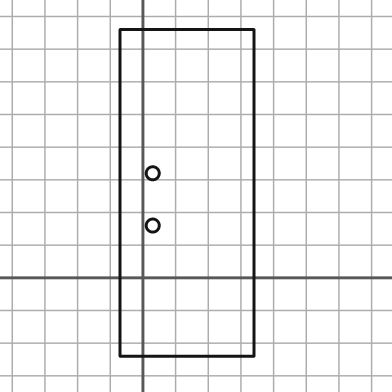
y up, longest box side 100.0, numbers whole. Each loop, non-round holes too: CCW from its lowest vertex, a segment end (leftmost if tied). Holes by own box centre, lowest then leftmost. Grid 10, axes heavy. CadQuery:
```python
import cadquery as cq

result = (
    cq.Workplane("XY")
    .moveTo(-7.0, -24.0)
    .lineTo(34.0, -24.0)
    .lineTo(34.0, 76.0)
    .lineTo(-7.0, 76.0)
    .close()
    .moveTo(3.0, 16.0)
    .circle(2.0)
    .moveTo(3.0, 32.0)
    .circle(2.0)
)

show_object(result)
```